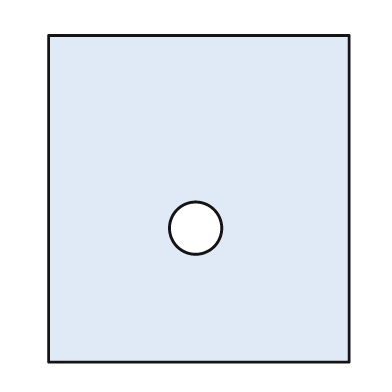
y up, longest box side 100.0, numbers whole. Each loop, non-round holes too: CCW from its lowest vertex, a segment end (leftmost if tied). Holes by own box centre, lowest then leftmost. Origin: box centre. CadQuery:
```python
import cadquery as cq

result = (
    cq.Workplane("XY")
    .moveTo(-46.0, -50.0)
    .lineTo(46.0, -50.0)
    .lineTo(46.0, 50.0)
    .lineTo(-46.0, 50.0)
    .close()
    .moveTo(-1.0, -9.0)
    .circle(8.0)
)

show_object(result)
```